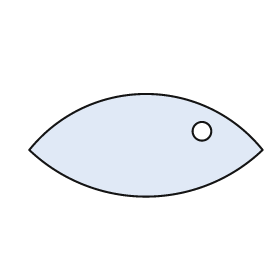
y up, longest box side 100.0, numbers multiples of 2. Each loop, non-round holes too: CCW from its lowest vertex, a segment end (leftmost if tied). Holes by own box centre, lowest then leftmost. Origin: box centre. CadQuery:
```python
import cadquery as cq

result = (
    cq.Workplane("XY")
    .moveTo(-50.0, -2.0)
    .threePointArc((0.0, -22.0), (50.0, -2.0))
    .threePointArc((0.0, 22.0), (-50.0, -2.0))
    .close()
    .moveTo(24.0, 6.0)
    .circle(4.0)
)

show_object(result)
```